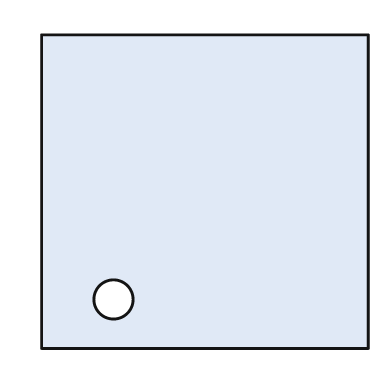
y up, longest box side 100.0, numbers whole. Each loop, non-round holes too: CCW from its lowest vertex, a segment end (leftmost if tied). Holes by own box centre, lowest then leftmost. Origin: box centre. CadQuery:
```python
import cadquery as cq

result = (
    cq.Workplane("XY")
    .moveTo(-50.0, -48.0)
    .lineTo(50.0, -48.0)
    .lineTo(50.0, 48.0)
    .lineTo(-50.0, 48.0)
    .close()
    .moveTo(-28.0, -33.0)
    .circle(6.0)
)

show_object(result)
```